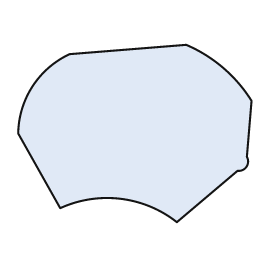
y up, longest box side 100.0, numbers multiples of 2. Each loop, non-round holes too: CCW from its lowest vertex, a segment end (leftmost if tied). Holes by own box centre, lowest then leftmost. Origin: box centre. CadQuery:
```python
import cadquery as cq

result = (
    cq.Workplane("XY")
    .moveTo(18.0, -38.0)
    .lineTo(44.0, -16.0)
    .threePointArc((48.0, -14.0), (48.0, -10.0))
    .lineTo(50.0, 14.0)
    .threePointArc((38.0, 28.0), (22.0, 38.0))
    .lineTo(-28.0, 34.0)
    .threePointArc((-44.0, 20.0), (-50.0, 0.0))
    .lineTo(-32.0, -32.0)
    .threePointArc((-6.0, -28.0), (18.0, -38.0))
    .close()
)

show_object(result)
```